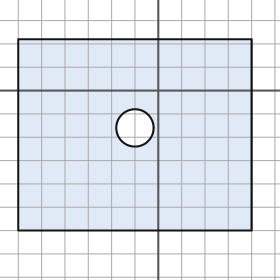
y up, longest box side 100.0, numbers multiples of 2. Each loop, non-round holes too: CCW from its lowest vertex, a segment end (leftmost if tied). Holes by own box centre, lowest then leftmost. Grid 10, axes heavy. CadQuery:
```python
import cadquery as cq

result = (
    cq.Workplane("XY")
    .moveTo(-60.0, -60.0)
    .lineTo(40.0, -60.0)
    .lineTo(40.0, 22.0)
    .lineTo(-60.0, 22.0)
    .close()
    .moveTo(-10.0, -16.0)
    .circle(8.0)
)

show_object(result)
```